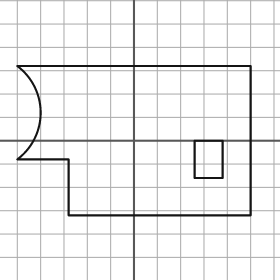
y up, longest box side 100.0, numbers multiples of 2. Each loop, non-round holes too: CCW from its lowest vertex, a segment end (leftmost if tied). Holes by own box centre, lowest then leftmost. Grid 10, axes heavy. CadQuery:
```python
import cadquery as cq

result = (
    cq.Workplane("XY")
    .moveTo(-28.0, -32.0)
    .lineTo(50.0, -32.0)
    .lineTo(50.0, 32.0)
    .lineTo(-50.0, 32.0)
    .threePointArc((-40.0, 12.0), (-50.0, -8.0))
    .lineTo(-28.0, -8.0)
    .close()
    .moveTo(26.0, -16.0)
    .lineTo(38.0, -16.0)
    .lineTo(38.0, 0.0)
    .lineTo(26.0, 0.0)
    .close()
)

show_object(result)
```